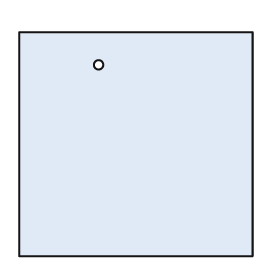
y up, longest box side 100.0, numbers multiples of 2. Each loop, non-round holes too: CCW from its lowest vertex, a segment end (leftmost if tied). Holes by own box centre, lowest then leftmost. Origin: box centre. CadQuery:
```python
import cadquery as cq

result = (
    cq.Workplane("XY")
    .moveTo(-50.0, -48.0)
    .lineTo(50.0, -48.0)
    .lineTo(50.0, 48.0)
    .lineTo(-50.0, 48.0)
    .close()
    .moveTo(-16.0, 34.0)
    .circle(2.0)
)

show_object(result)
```